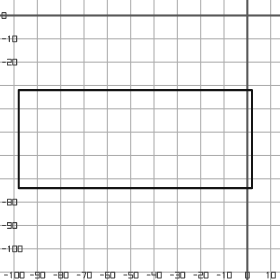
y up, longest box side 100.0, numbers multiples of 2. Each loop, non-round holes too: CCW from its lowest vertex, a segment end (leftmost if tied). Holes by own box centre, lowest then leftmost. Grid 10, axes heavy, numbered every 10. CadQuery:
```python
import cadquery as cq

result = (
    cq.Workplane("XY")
    .moveTo(-98.0, -74.0)
    .lineTo(2.0, -74.0)
    .lineTo(2.0, -32.0)
    .lineTo(-98.0, -32.0)
    .close()
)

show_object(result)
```